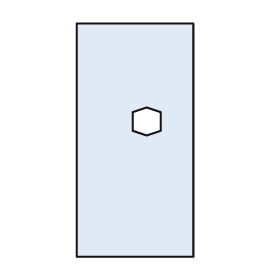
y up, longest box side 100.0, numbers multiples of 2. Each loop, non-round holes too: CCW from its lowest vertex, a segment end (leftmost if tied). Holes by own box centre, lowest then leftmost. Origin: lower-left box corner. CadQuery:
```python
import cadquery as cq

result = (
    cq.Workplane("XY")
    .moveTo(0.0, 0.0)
    .lineTo(50.0, 0.0)
    .lineTo(50.0, 100.0)
    .lineTo(0.0, 100.0)
    .close()
    .moveTo(30.0, 52.0)
    .lineTo(36.0, 54.0)
    .lineTo(36.0, 62.0)
    .lineTo(30.0, 64.0)
    .lineTo(24.0, 62.0)
    .lineTo(24.0, 54.0)
    .close()
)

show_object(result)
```